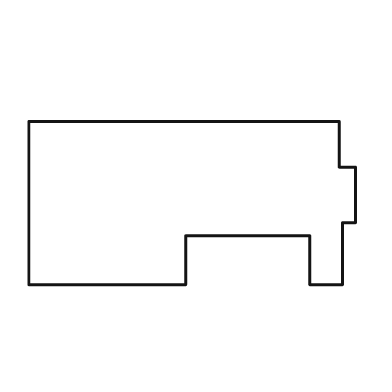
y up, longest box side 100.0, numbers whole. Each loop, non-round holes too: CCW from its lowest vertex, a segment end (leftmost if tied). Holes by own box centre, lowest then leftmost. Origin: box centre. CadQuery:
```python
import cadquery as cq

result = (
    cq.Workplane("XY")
    .moveTo(-50.0, -25.0)
    .lineTo(-2.0, -25.0)
    .lineTo(-2.0, -10.0)
    .lineTo(36.0, -10.0)
    .lineTo(36.0, -25.0)
    .lineTo(46.0, -25.0)
    .lineTo(46.0, -6.0)
    .lineTo(50.0, -6.0)
    .lineTo(50.0, 11.0)
    .lineTo(45.0, 11.0)
    .lineTo(45.0, 25.0)
    .lineTo(-50.0, 25.0)
    .close()
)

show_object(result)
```